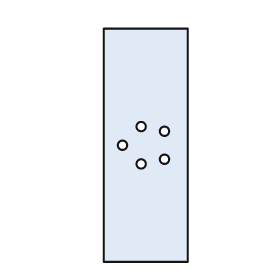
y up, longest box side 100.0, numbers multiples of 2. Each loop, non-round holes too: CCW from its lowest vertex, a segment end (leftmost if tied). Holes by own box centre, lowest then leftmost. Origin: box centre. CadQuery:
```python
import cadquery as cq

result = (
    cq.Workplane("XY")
    .moveTo(-18.0, -50.0)
    .lineTo(18.0, -50.0)
    .lineTo(18.0, 50.0)
    .lineTo(-18.0, 50.0)
    .close()
    .moveTo(-2.0, -8.0)
    .circle(2.0)
    .moveTo(8.0, -6.0)
    .circle(2.0)
    .moveTo(-10.0, 0.0)
    .circle(2.0)
    .moveTo(8.0, 6.0)
    .circle(2.0)
    .moveTo(-2.0, 8.0)
    .circle(2.0)
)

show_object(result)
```